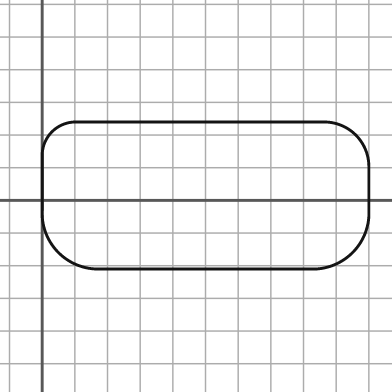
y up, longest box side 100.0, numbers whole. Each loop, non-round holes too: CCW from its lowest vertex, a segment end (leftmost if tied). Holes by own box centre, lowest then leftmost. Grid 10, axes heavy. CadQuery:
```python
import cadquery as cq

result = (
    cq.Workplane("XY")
    .moveTo(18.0, -21.0)
    .lineTo(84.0, -21.0)
    .threePointArc((95.0, -16.0), (100.0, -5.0))
    .lineTo(100.0, 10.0)
    .threePointArc((96.0, 20.0), (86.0, 24.0))
    .lineTo(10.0, 24.0)
    .threePointArc((3.0, 21.0), (0.0, 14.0))
    .lineTo(0.0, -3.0)
    .threePointArc((5.0, -16.0), (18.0, -21.0))
    .close()
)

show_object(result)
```